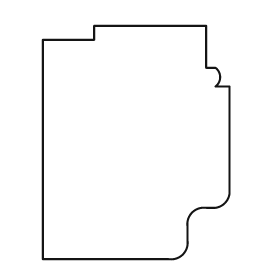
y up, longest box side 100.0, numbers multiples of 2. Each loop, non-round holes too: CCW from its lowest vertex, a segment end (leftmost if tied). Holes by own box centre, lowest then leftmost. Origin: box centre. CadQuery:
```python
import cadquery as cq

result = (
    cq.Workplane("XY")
    .moveTo(-40.0, -50.0)
    .lineTo(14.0, -50.0)
    .threePointArc((20.0, -48.0), (22.0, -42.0))
    .lineTo(22.0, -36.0)
    .threePointArc((24.0, -30.0), (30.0, -28.0))
    .lineTo(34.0, -28.0)
    .threePointArc((38.0, -26.0), (40.0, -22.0))
    .lineTo(40.0, 24.0)
    .lineTo(34.0, 24.0)
    .threePointArc((36.0, 28.0), (34.0, 32.0))
    .lineTo(30.0, 32.0)
    .lineTo(30.0, 50.0)
    .lineTo(-18.0, 50.0)
    .lineTo(-18.0, 44.0)
    .lineTo(-40.0, 44.0)
    .close()
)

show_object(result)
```